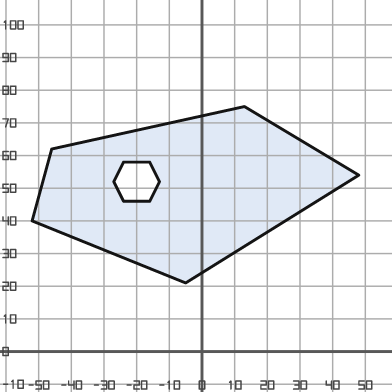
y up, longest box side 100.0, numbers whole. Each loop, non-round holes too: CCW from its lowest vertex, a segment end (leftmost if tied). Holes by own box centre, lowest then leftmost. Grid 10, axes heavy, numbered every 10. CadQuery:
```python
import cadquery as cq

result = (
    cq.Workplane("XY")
    .moveTo(-5.0, 21.0)
    .lineTo(48.0, 54.0)
    .lineTo(13.0, 75.0)
    .lineTo(-46.0, 62.0)
    .lineTo(-52.0, 40.0)
    .close()
    .moveTo(-24.0, 46.0)
    .lineTo(-16.0, 46.0)
    .lineTo(-13.0, 52.0)
    .lineTo(-16.0, 58.0)
    .lineTo(-24.0, 58.0)
    .lineTo(-27.0, 52.0)
    .close()
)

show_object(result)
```